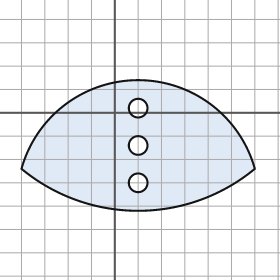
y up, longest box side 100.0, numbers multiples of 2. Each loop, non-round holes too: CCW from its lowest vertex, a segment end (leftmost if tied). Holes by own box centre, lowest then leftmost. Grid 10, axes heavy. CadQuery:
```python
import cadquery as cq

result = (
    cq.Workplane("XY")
    .moveTo(-40.0, -24.0)
    .threePointArc((10.0, -42.0), (60.0, -24.0))
    .threePointArc((10.0, 14.0), (-40.0, -24.0))
    .close()
    .moveTo(10.0, -30.0)
    .circle(4.0)
    .moveTo(10.0, -14.0)
    .circle(4.0)
    .moveTo(10.0, 2.0)
    .circle(4.0)
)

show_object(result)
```